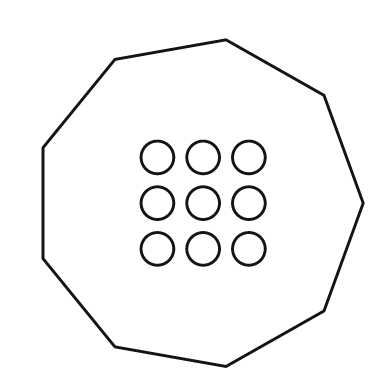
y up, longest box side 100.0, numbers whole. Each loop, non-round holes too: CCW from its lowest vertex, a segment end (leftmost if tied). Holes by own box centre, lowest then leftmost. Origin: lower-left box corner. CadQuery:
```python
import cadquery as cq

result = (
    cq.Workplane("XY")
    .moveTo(56.0, 0.0)
    .lineTo(86.0, 17.0)
    .lineTo(98.0, 50.0)
    .lineTo(86.0, 83.0)
    .lineTo(56.0, 100.0)
    .lineTo(22.0, 94.0)
    .lineTo(0.0, 67.0)
    .lineTo(0.0, 33.0)
    .lineTo(22.0, 6.0)
    .close()
    .moveTo(35.0, 36.0)
    .circle(5.0)
    .moveTo(49.0, 36.0)
    .circle(5.0)
    .moveTo(63.0, 36.0)
    .circle(5.0)
    .moveTo(35.0, 50.0)
    .circle(5.0)
    .moveTo(49.0, 50.0)
    .circle(5.0)
    .moveTo(63.0, 50.0)
    .circle(5.0)
    .moveTo(35.0, 64.0)
    .circle(5.0)
    .moveTo(49.0, 64.0)
    .circle(5.0)
    .moveTo(63.0, 64.0)
    .circle(5.0)
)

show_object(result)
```